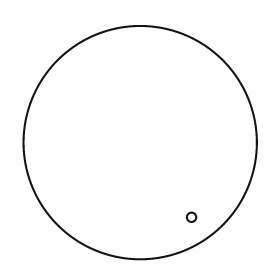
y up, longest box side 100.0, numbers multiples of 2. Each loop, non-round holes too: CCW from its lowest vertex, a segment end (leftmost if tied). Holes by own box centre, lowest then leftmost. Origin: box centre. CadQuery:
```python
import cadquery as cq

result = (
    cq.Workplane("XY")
    .moveTo(0.0, 0.0)
    .circle(50.0)
    .moveTo(22.0, -32.0)
    .circle(2.0)
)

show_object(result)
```